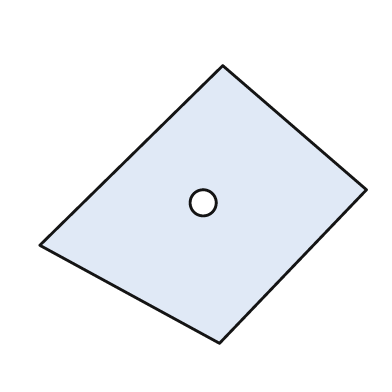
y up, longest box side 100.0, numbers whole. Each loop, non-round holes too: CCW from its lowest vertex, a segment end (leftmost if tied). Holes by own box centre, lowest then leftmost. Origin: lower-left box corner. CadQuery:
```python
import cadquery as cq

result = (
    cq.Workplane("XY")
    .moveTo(55.0, 0.0)
    .lineTo(100.0, 47.0)
    .lineTo(56.0, 85.0)
    .lineTo(0.0, 30.0)
    .close()
    .moveTo(50.0, 43.0)
    .circle(4.0)
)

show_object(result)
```